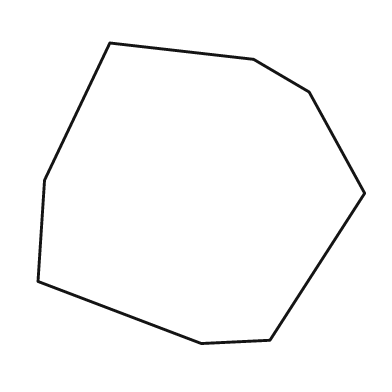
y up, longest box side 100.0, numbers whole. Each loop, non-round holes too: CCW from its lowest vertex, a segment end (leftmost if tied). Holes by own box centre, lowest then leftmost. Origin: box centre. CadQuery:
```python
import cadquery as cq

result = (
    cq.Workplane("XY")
    .moveTo(0.0, -46.0)
    .lineTo(21.0, -45.0)
    .lineTo(50.0, 0.0)
    .lineTo(33.0, 31.0)
    .lineTo(16.0, 41.0)
    .lineTo(-28.0, 46.0)
    .lineTo(-48.0, 4.0)
    .lineTo(-50.0, -27.0)
    .close()
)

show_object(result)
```